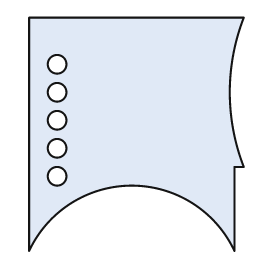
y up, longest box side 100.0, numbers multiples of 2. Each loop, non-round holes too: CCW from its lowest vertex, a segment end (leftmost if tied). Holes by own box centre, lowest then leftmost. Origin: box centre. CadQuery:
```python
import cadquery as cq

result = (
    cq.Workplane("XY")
    .moveTo(-46.0, -50.0)
    .threePointArc((-2.0, -22.0), (42.0, -50.0))
    .lineTo(42.0, -14.0)
    .lineTo(46.0, -14.0)
    .threePointArc((40.0, 18.0), (46.0, 50.0))
    .lineTo(-46.0, 50.0)
    .close()
    .moveTo(-34.0, -18.0)
    .circle(4.0)
    .moveTo(-34.0, -6.0)
    .circle(4.0)
    .moveTo(-34.0, 6.0)
    .circle(4.0)
    .moveTo(-34.0, 18.0)
    .circle(4.0)
    .moveTo(-34.0, 30.0)
    .circle(4.0)
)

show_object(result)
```